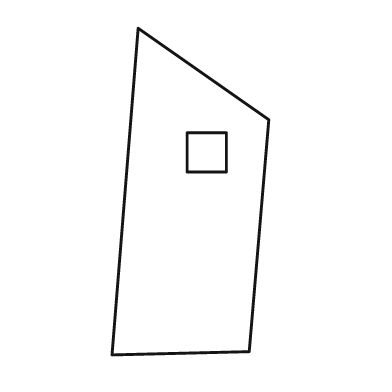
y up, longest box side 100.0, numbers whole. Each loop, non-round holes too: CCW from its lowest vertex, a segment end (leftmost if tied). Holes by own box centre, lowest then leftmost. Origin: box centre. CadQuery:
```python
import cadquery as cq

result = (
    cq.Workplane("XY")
    .moveTo(-24.0, -50.0)
    .lineTo(18.0, -49.0)
    .lineTo(24.0, 22.0)
    .lineTo(-16.0, 50.0)
    .close()
    .moveTo(-1.0, 6.0)
    .lineTo(11.0, 6.0)
    .lineTo(11.0, 18.0)
    .lineTo(-1.0, 18.0)
    .close()
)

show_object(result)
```